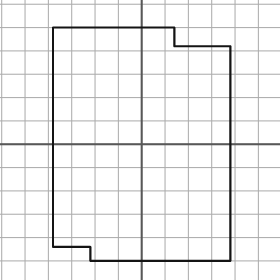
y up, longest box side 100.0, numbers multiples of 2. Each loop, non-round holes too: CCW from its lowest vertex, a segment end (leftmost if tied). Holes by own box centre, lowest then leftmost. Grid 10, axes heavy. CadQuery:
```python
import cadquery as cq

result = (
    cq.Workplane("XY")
    .moveTo(-22.0, -50.0)
    .lineTo(38.0, -50.0)
    .lineTo(38.0, 42.0)
    .lineTo(14.0, 42.0)
    .lineTo(14.0, 50.0)
    .lineTo(-38.0, 50.0)
    .lineTo(-38.0, -44.0)
    .lineTo(-22.0, -44.0)
    .close()
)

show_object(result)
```